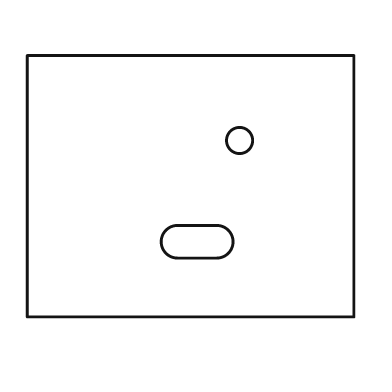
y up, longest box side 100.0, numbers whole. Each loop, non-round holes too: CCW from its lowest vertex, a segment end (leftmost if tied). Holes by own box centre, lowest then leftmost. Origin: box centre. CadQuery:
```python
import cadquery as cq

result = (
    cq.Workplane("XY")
    .moveTo(-50.0, -40.0)
    .lineTo(50.0, -40.0)
    .lineTo(50.0, 40.0)
    .lineTo(-50.0, 40.0)
    .close()
    .moveTo(-4.0, -22.0)
    .lineTo(8.0, -22.0)
    .threePointArc((13.0, -17.0), (8.0, -12.0))
    .lineTo(-4.0, -12.0)
    .threePointArc((-9.0, -17.0), (-4.0, -22.0))
    .close()
    .moveTo(15.0, 14.0)
    .circle(4.0)
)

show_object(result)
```